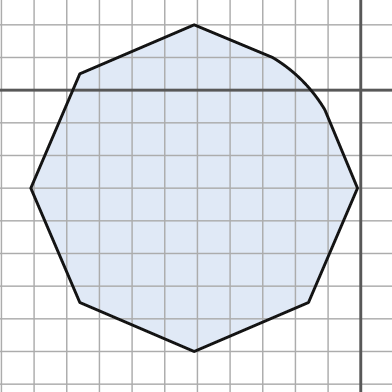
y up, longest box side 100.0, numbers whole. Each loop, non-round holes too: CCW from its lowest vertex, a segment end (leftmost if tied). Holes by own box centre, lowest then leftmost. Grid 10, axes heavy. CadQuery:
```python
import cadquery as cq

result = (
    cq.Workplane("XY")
    .moveTo(-51.0, -80.0)
    .lineTo(-16.0, -65.0)
    .lineTo(-1.0, -30.0)
    .lineTo(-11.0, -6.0)
    .threePointArc((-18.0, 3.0), (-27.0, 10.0))
    .lineTo(-51.0, 20.0)
    .lineTo(-86.0, 5.0)
    .lineTo(-101.0, -30.0)
    .lineTo(-86.0, -65.0)
    .close()
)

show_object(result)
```